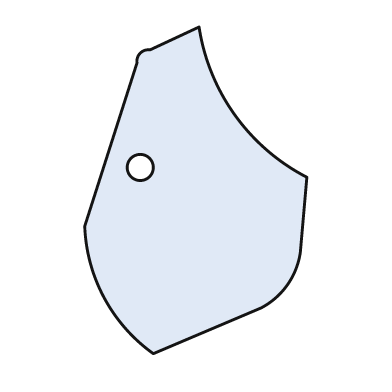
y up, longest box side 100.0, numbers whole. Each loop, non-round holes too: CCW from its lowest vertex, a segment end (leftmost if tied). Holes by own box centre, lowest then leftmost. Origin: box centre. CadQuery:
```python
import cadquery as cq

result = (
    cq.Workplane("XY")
    .moveTo(-13.0, -50.0)
    .lineTo(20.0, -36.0)
    .threePointArc((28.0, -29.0), (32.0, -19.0))
    .lineTo(34.0, 4.0)
    .threePointArc((12.0, 23.0), (1.0, 50.0))
    .lineTo(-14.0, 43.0)
    .threePointArc((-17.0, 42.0), (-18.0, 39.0))
    .lineTo(-34.0, -11.0)
    .threePointArc((-28.0, -33.0), (-13.0, -50.0))
    .close()
    .moveTo(-17.0, 7.0)
    .circle(4.0)
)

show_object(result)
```